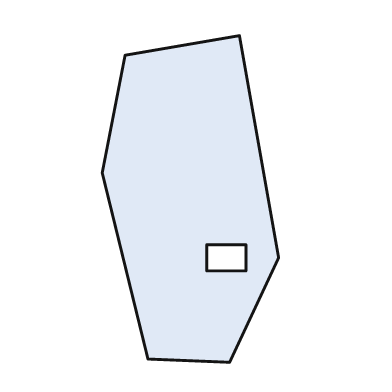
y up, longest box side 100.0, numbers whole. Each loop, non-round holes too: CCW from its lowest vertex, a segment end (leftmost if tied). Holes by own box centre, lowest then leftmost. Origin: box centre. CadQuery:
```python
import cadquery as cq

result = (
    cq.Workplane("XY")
    .moveTo(12.0, -50.0)
    .lineTo(27.0, -18.0)
    .lineTo(15.0, 50.0)
    .lineTo(-20.0, 44.0)
    .lineTo(-27.0, 8.0)
    .lineTo(-13.0, -49.0)
    .close()
    .moveTo(5.0, -22.0)
    .lineTo(17.0, -22.0)
    .lineTo(17.0, -14.0)
    .lineTo(5.0, -14.0)
    .close()
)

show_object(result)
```